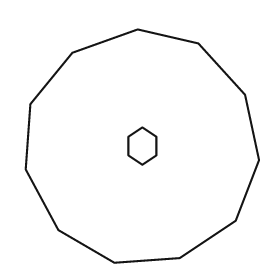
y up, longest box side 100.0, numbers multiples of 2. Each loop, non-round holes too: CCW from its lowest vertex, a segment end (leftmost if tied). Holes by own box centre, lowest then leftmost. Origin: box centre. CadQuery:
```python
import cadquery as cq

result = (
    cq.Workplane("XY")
    .moveTo(-12.0, -50.0)
    .lineTo(16.0, -48.0)
    .lineTo(40.0, -32.0)
    .lineTo(50.0, -6.0)
    .lineTo(44.0, 22.0)
    .lineTo(24.0, 44.0)
    .lineTo(-2.0, 50.0)
    .lineTo(-30.0, 40.0)
    .lineTo(-48.0, 18.0)
    .lineTo(-50.0, -10.0)
    .lineTo(-36.0, -36.0)
    .close()
    .moveTo(0.0, -8.0)
    .lineTo(6.0, -4.0)
    .lineTo(6.0, 4.0)
    .lineTo(0.0, 8.0)
    .lineTo(-6.0, 4.0)
    .lineTo(-6.0, -4.0)
    .close()
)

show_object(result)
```